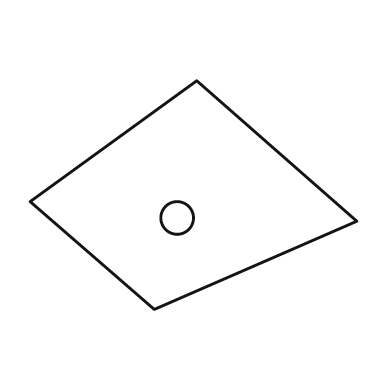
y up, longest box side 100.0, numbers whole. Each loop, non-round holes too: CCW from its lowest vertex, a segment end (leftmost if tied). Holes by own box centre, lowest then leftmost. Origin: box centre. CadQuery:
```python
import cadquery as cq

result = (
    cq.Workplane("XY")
    .moveTo(-12.0, -35.0)
    .lineTo(50.0, -8.0)
    .lineTo(1.0, 35.0)
    .lineTo(-50.0, -2.0)
    .close()
    .moveTo(-5.0, -7.0)
    .circle(5.0)
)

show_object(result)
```